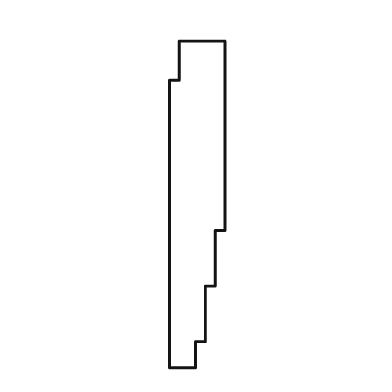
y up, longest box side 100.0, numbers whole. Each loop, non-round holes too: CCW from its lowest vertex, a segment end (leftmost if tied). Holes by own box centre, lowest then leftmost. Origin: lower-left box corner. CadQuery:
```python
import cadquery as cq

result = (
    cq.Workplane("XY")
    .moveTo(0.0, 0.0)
    .lineTo(8.0, 0.0)
    .lineTo(8.0, 8.0)
    .lineTo(11.0, 8.0)
    .lineTo(11.0, 25.0)
    .lineTo(14.0, 25.0)
    .lineTo(14.0, 42.0)
    .lineTo(17.0, 42.0)
    .lineTo(17.0, 100.0)
    .lineTo(3.0, 100.0)
    .lineTo(3.0, 88.0)
    .lineTo(0.0, 88.0)
    .close()
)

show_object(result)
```